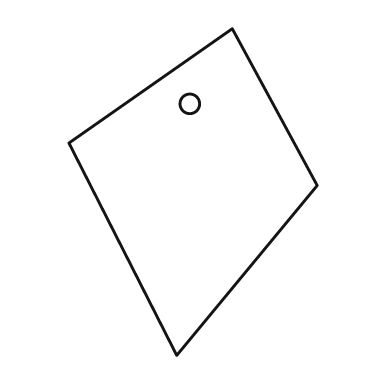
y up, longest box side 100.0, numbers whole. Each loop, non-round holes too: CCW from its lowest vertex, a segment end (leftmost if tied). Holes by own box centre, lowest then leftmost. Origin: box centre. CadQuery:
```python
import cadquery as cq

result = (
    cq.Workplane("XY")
    .moveTo(-5.0, -50.0)
    .lineTo(38.0, 2.0)
    .lineTo(12.0, 50.0)
    .lineTo(-38.0, 15.0)
    .close()
    .moveTo(-1.0, 27.0)
    .circle(3.0)
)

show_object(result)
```